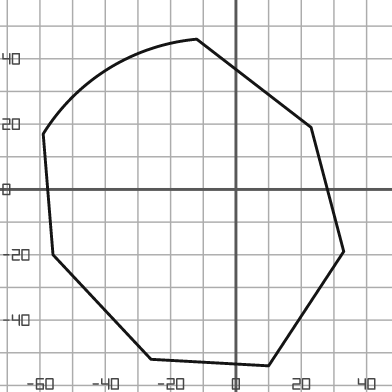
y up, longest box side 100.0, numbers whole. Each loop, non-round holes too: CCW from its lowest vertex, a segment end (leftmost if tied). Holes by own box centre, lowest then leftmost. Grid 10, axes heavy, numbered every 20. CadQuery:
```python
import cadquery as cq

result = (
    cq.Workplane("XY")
    .moveTo(10.0, -54.0)
    .lineTo(33.0, -19.0)
    .lineTo(23.0, 19.0)
    .lineTo(-12.0, 46.0)
    .threePointArc((-39.0, 37.0), (-59.0, 17.0))
    .lineTo(-56.0, -20.0)
    .lineTo(-26.0, -52.0)
    .close()
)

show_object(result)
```